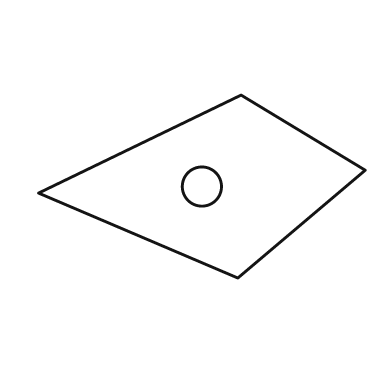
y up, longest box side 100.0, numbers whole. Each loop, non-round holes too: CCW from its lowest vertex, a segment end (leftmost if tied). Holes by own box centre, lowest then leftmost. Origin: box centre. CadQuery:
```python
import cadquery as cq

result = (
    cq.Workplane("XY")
    .moveTo(11.0, -28.0)
    .lineTo(50.0, 5.0)
    .lineTo(12.0, 28.0)
    .lineTo(-50.0, -2.0)
    .close()
    .moveTo(0.0, 0.0)
    .circle(6.0)
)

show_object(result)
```